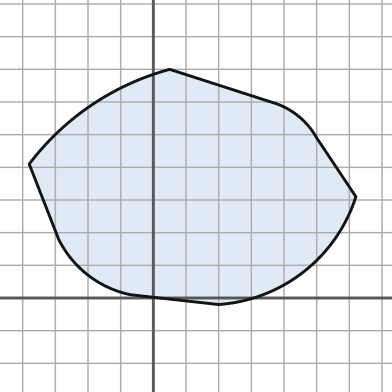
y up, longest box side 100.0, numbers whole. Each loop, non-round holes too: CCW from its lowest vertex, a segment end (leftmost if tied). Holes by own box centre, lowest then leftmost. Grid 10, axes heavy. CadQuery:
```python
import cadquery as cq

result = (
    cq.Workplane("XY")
    .moveTo(20.0, -2.0)
    .threePointArc((46.0, 8.0), (62.0, 31.0))
    .lineTo(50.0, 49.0)
    .threePointArc((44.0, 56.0), (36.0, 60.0))
    .lineTo(5.0, 70.0)
    .threePointArc((-19.0, 59.0), (-38.0, 41.0))
    .lineTo(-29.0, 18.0)
    .threePointArc((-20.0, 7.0), (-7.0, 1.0))
    .close()
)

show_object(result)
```